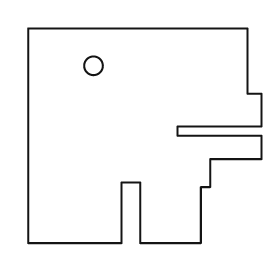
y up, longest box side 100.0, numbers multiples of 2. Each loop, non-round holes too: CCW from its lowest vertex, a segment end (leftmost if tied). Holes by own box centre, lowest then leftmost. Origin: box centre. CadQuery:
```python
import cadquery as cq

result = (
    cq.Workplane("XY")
    .moveTo(-50.0, -46.0)
    .lineTo(-10.0, -46.0)
    .lineTo(-10.0, -20.0)
    .lineTo(-2.0, -20.0)
    .lineTo(-2.0, -46.0)
    .lineTo(24.0, -46.0)
    .lineTo(24.0, -22.0)
    .lineTo(28.0, -22.0)
    .lineTo(28.0, -10.0)
    .lineTo(50.0, -10.0)
    .lineTo(50.0, 0.0)
    .lineTo(14.0, 0.0)
    .lineTo(14.0, 4.0)
    .lineTo(50.0, 4.0)
    .lineTo(50.0, 18.0)
    .lineTo(44.0, 18.0)
    .lineTo(44.0, 46.0)
    .lineTo(-50.0, 46.0)
    .close()
    .moveTo(-22.0, 30.0)
    .circle(4.0)
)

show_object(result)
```